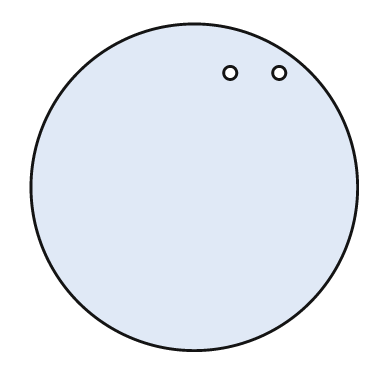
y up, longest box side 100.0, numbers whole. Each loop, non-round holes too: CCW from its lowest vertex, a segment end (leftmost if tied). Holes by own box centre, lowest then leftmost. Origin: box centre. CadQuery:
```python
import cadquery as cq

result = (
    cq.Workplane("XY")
    .moveTo(0.0, 0.0)
    .circle(50.0)
    .moveTo(11.0, 35.0)
    .circle(2.0)
    .moveTo(26.0, 35.0)
    .circle(2.0)
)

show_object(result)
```